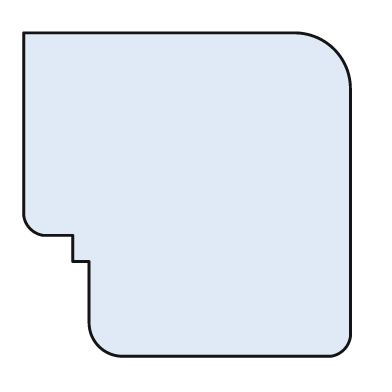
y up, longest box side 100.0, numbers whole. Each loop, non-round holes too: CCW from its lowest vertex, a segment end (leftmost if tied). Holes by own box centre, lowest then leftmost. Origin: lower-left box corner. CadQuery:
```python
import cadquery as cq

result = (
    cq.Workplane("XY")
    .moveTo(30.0, 0.0)
    .lineTo(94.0, 0.0)
    .threePointArc((98.0, 2.0), (100.0, 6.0))
    .lineTo(100.0, 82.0)
    .threePointArc((95.0, 94.0), (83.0, 99.0))
    .lineTo(0.0, 99.0)
    .lineTo(0.0, 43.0)
    .threePointArc((2.0, 39.0), (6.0, 37.0))
    .lineTo(15.0, 37.0)
    .lineTo(15.0, 29.0)
    .lineTo(20.0, 29.0)
    .lineTo(20.0, 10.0)
    .threePointArc((23.0, 3.0), (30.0, 0.0))
    .close()
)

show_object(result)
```